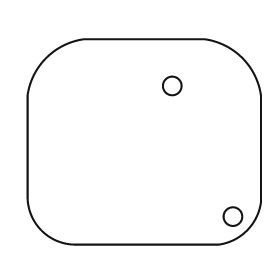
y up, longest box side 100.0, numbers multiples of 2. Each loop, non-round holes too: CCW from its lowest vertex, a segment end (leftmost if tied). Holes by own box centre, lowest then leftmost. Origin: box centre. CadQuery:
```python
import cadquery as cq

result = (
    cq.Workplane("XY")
    .moveTo(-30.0, -44.0)
    .lineTo(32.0, -44.0)
    .threePointArc((44.0, -38.0), (50.0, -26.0))
    .lineTo(50.0, 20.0)
    .threePointArc((42.0, 36.0), (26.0, 44.0))
    .lineTo(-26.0, 44.0)
    .threePointArc((-42.0, 36.0), (-50.0, 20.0))
    .lineTo(-50.0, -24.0)
    .threePointArc((-44.0, -38.0), (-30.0, -44.0))
    .close()
    .moveTo(38.0, -32.0)
    .circle(4.0)
    .moveTo(12.0, 24.0)
    .circle(4.0)
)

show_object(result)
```